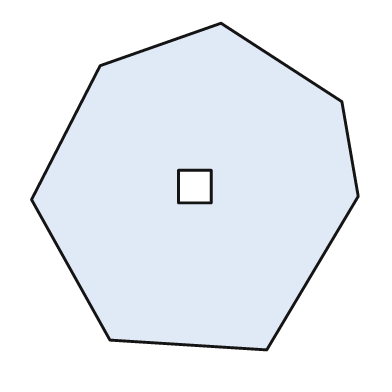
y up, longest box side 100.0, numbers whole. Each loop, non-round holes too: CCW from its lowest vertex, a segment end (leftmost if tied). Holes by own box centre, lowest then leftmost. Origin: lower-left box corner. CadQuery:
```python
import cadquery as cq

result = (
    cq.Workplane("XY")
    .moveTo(72.0, 0.0)
    .lineTo(100.0, 47.0)
    .lineTo(95.0, 76.0)
    .lineTo(58.0, 100.0)
    .lineTo(21.0, 87.0)
    .lineTo(0.0, 46.0)
    .lineTo(24.0, 3.0)
    .close()
    .moveTo(45.0, 45.0)
    .lineTo(55.0, 45.0)
    .lineTo(55.0, 55.0)
    .lineTo(45.0, 55.0)
    .close()
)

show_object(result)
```